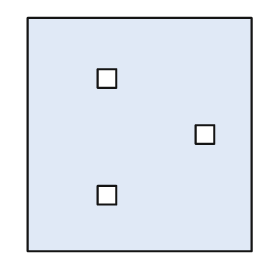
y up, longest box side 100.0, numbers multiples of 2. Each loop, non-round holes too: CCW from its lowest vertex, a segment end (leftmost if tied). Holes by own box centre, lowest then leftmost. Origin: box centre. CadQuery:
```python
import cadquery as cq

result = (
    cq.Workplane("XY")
    .moveTo(-48.0, -50.0)
    .lineTo(48.0, -50.0)
    .lineTo(48.0, 50.0)
    .lineTo(-48.0, 50.0)
    .close()
    .moveTo(-18.0, -30.0)
    .lineTo(-10.0, -30.0)
    .lineTo(-10.0, -22.0)
    .lineTo(-18.0, -22.0)
    .close()
    .moveTo(24.0, -4.0)
    .lineTo(32.0, -4.0)
    .lineTo(32.0, 4.0)
    .lineTo(24.0, 4.0)
    .close()
    .moveTo(-18.0, 20.0)
    .lineTo(-10.0, 20.0)
    .lineTo(-10.0, 28.0)
    .lineTo(-18.0, 28.0)
    .close()
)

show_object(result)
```